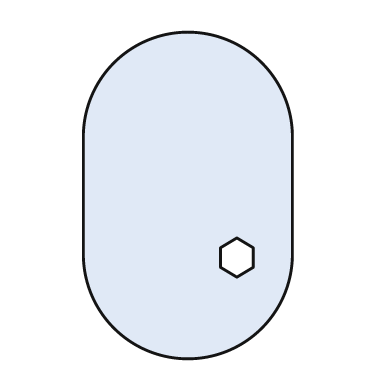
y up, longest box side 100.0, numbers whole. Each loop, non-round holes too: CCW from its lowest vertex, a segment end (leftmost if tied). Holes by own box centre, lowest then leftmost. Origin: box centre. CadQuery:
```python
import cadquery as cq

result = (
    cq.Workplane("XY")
    .moveTo(-32.0, -18.0)
    .threePointArc((0.0, -50.0), (32.0, -18.0))
    .lineTo(32.0, 18.0)
    .threePointArc((0.0, 50.0), (-32.0, 18.0))
    .close()
    .moveTo(15.0, -25.0)
    .lineTo(20.0, -22.0)
    .lineTo(20.0, -16.0)
    .lineTo(15.0, -13.0)
    .lineTo(10.0, -16.0)
    .lineTo(10.0, -22.0)
    .close()
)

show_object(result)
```